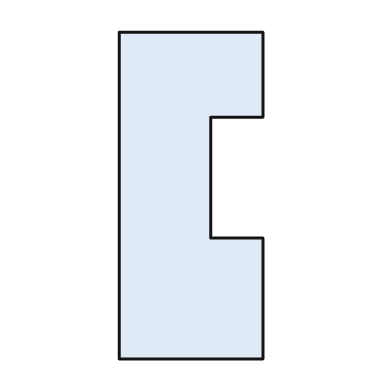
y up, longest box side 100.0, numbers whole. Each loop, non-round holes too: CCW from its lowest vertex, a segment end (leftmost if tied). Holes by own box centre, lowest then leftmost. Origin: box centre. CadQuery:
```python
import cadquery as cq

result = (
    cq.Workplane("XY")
    .moveTo(-22.0, -50.0)
    .lineTo(22.0, -50.0)
    .lineTo(22.0, -13.0)
    .lineTo(6.0, -13.0)
    .lineTo(6.0, 24.0)
    .lineTo(22.0, 24.0)
    .lineTo(22.0, 50.0)
    .lineTo(-22.0, 50.0)
    .close()
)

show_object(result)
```